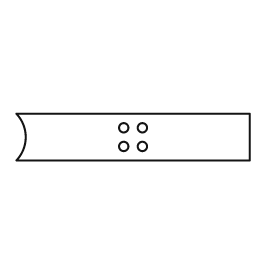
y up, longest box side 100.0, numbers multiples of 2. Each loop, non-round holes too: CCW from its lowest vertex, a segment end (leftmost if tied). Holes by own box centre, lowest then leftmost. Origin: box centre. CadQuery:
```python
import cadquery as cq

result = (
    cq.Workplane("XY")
    .moveTo(-50.0, -10.0)
    .lineTo(50.0, -10.0)
    .lineTo(50.0, 10.0)
    .lineTo(-50.0, 10.0)
    .threePointArc((-46.0, 0.0), (-50.0, -10.0))
    .close()
    .moveTo(-4.0, -4.0)
    .circle(2.0)
    .moveTo(4.0, -4.0)
    .circle(2.0)
    .moveTo(-4.0, 4.0)
    .circle(2.0)
    .moveTo(4.0, 4.0)
    .circle(2.0)
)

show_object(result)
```